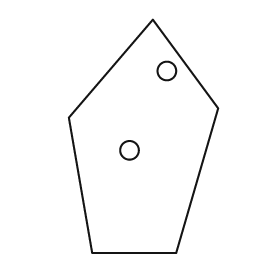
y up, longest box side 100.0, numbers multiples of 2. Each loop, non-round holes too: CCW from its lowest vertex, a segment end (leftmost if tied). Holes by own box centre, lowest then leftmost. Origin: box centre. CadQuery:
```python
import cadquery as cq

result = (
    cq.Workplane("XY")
    .moveTo(-22.0, -50.0)
    .lineTo(14.0, -50.0)
    .lineTo(32.0, 12.0)
    .lineTo(4.0, 50.0)
    .lineTo(-32.0, 8.0)
    .close()
    .moveTo(-6.0, -6.0)
    .circle(4.0)
    .moveTo(10.0, 28.0)
    .circle(4.0)
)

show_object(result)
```